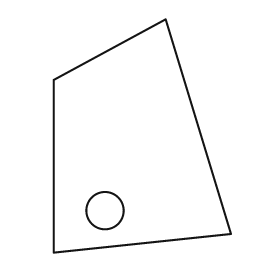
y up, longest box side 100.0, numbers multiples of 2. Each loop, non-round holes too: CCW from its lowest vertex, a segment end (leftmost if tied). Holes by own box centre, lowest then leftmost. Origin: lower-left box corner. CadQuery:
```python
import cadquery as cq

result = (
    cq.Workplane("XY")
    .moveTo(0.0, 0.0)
    .lineTo(76.0, 8.0)
    .lineTo(48.0, 100.0)
    .lineTo(0.0, 74.0)
    .close()
    .moveTo(22.0, 18.0)
    .circle(8.0)
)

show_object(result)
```